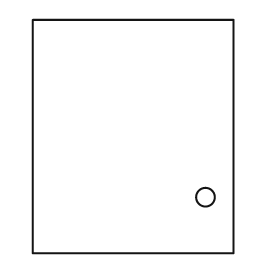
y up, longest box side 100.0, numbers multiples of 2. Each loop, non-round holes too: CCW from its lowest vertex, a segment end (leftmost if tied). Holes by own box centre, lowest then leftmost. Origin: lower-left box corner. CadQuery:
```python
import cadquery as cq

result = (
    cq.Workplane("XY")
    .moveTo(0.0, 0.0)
    .lineTo(86.0, 0.0)
    .lineTo(86.0, 100.0)
    .lineTo(0.0, 100.0)
    .close()
    .moveTo(74.0, 24.0)
    .circle(4.0)
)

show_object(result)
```